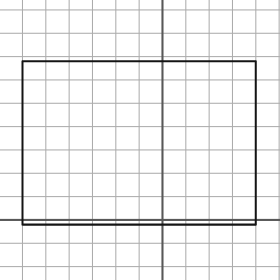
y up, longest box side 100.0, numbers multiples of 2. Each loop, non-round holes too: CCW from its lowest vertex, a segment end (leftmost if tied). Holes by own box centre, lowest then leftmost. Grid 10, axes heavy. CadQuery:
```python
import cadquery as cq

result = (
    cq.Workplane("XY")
    .moveTo(-60.0, -2.0)
    .lineTo(40.0, -2.0)
    .lineTo(40.0, 68.0)
    .lineTo(-60.0, 68.0)
    .close()
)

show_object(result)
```